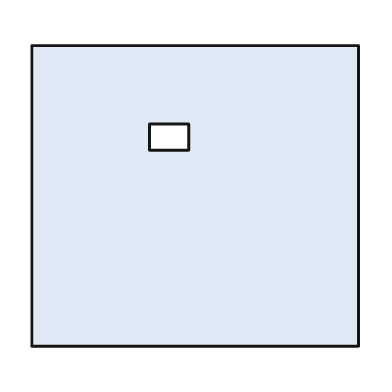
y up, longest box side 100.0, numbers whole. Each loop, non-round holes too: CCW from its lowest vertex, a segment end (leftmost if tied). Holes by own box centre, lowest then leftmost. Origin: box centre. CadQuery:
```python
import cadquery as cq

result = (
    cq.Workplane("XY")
    .moveTo(-50.0, -46.0)
    .lineTo(50.0, -46.0)
    .lineTo(50.0, 46.0)
    .lineTo(-50.0, 46.0)
    .close()
    .moveTo(-14.0, 14.0)
    .lineTo(-2.0, 14.0)
    .lineTo(-2.0, 22.0)
    .lineTo(-14.0, 22.0)
    .close()
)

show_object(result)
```